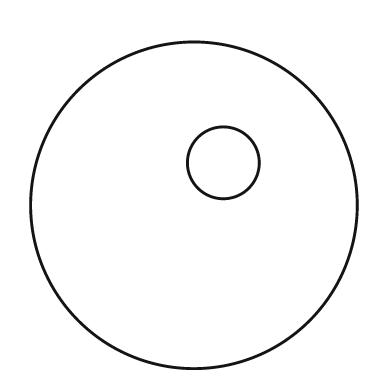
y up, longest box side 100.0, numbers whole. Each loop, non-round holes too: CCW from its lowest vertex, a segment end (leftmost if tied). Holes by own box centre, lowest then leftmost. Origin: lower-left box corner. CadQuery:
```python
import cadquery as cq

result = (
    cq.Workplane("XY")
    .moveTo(50.0, 50.0)
    .circle(50.0)
    .moveTo(59.0, 63.0)
    .circle(11.0)
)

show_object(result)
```